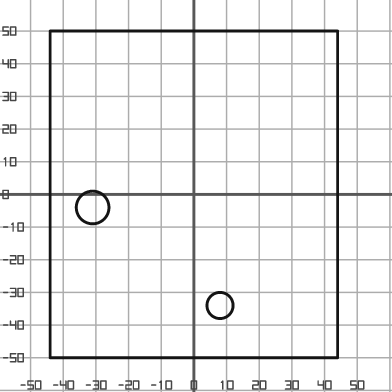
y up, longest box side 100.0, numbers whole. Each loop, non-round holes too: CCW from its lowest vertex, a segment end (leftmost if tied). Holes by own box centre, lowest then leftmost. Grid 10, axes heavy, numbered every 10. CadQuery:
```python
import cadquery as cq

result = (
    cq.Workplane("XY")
    .moveTo(-44.0, -50.0)
    .lineTo(44.0, -50.0)
    .lineTo(44.0, 50.0)
    .lineTo(-44.0, 50.0)
    .close()
    .moveTo(8.0, -34.0)
    .circle(4.0)
    .moveTo(-31.0, -4.0)
    .circle(5.0)
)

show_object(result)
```